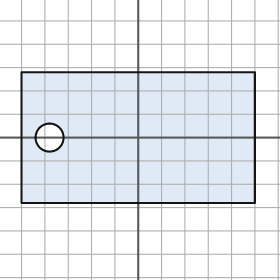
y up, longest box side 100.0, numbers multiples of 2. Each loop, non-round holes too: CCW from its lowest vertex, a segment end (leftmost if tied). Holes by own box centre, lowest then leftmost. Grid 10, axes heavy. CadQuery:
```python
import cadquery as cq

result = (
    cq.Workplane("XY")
    .moveTo(-50.0, -28.0)
    .lineTo(50.0, -28.0)
    .lineTo(50.0, 28.0)
    .lineTo(-50.0, 28.0)
    .close()
    .moveTo(-38.0, 0.0)
    .circle(6.0)
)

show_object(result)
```